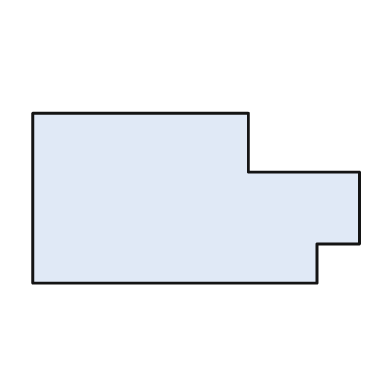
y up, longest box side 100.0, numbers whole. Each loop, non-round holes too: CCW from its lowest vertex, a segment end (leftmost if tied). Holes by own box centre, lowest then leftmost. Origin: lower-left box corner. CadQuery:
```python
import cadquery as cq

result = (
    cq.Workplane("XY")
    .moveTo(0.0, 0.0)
    .lineTo(87.0, 0.0)
    .lineTo(87.0, 12.0)
    .lineTo(100.0, 12.0)
    .lineTo(100.0, 34.0)
    .lineTo(66.0, 34.0)
    .lineTo(66.0, 52.0)
    .lineTo(0.0, 52.0)
    .close()
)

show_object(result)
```